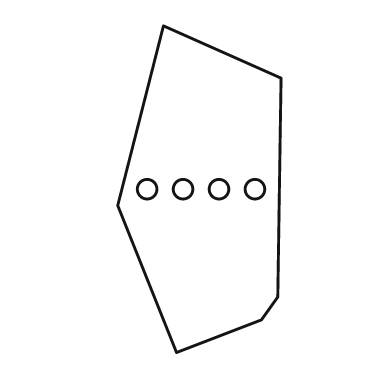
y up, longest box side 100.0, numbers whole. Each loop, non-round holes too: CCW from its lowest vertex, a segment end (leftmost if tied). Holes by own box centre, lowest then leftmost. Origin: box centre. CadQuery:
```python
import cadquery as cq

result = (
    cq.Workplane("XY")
    .moveTo(-7.0, -50.0)
    .lineTo(19.0, -40.0)
    .lineTo(24.0, -33.0)
    .lineTo(25.0, 34.0)
    .lineTo(-11.0, 50.0)
    .lineTo(-25.0, -5.0)
    .close()
    .moveTo(-16.0, 0.0)
    .circle(3.0)
    .moveTo(-5.0, 0.0)
    .circle(3.0)
    .moveTo(6.0, 0.0)
    .circle(3.0)
    .moveTo(17.0, 0.0)
    .circle(3.0)
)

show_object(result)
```